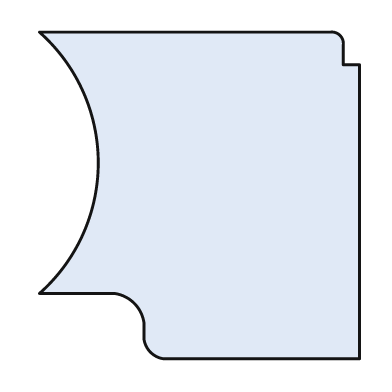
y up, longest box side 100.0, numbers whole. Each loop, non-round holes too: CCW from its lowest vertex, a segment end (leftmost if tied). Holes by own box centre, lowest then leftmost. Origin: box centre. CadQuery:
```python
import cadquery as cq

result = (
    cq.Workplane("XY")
    .moveTo(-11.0, -50.0)
    .lineTo(49.0, -50.0)
    .lineTo(49.0, 40.0)
    .lineTo(44.0, 40.0)
    .lineTo(44.0, 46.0)
    .threePointArc((43.0, 49.0), (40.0, 50.0))
    .lineTo(-49.0, 50.0)
    .threePointArc((-31.0, 10.0), (-49.0, -30.0))
    .lineTo(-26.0, -30.0)
    .threePointArc((-20.0, -33.0), (-17.0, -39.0))
    .lineTo(-17.0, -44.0)
    .threePointArc((-15.0, -48.0), (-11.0, -50.0))
    .close()
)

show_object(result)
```